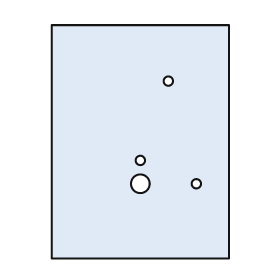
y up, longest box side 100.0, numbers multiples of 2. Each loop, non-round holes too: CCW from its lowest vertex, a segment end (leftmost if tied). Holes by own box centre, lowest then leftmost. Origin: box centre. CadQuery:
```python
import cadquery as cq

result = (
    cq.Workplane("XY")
    .moveTo(-38.0, -50.0)
    .lineTo(38.0, -50.0)
    .lineTo(38.0, 50.0)
    .lineTo(-38.0, 50.0)
    .close()
    .moveTo(0.0, -18.0)
    .circle(4.0)
    .moveTo(24.0, -18.0)
    .circle(2.0)
    .moveTo(0.0, -8.0)
    .circle(2.0)
    .moveTo(12.0, 26.0)
    .circle(2.0)
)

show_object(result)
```